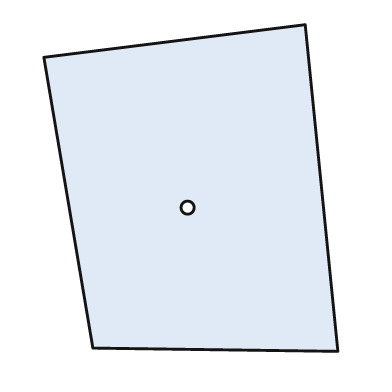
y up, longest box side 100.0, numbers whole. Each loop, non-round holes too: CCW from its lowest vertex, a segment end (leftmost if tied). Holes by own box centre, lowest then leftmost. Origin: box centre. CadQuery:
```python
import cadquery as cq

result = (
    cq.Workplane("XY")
    .moveTo(45.0, -50.0)
    .lineTo(35.0, 50.0)
    .lineTo(-45.0, 40.0)
    .lineTo(-30.0, -49.0)
    .close()
    .moveTo(-1.0, -6.0)
    .circle(2.0)
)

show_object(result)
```